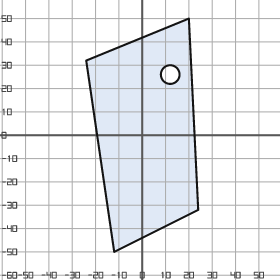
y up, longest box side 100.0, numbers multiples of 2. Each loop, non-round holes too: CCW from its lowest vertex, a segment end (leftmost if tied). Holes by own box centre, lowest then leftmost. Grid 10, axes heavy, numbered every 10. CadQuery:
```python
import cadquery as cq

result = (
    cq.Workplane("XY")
    .moveTo(-12.0, -50.0)
    .lineTo(24.0, -32.0)
    .lineTo(20.0, 50.0)
    .lineTo(-24.0, 32.0)
    .close()
    .moveTo(12.0, 26.0)
    .circle(4.0)
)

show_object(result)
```